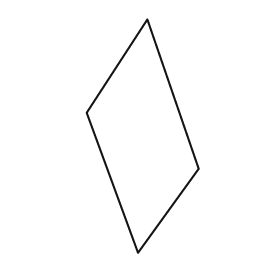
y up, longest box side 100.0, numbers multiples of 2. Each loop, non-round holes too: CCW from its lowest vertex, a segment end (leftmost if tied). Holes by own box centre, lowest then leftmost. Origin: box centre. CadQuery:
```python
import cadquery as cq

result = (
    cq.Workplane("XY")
    .moveTo(-2.0, -50.0)
    .lineTo(24.0, -14.0)
    .lineTo(2.0, 50.0)
    .lineTo(-24.0, 10.0)
    .close()
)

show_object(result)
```